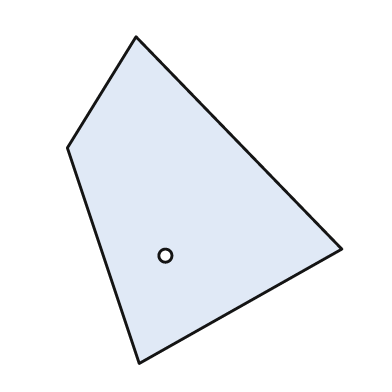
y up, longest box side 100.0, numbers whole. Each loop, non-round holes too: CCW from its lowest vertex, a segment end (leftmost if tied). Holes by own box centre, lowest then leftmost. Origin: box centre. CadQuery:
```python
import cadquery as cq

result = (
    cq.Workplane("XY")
    .moveTo(-20.0, -50.0)
    .lineTo(42.0, -15.0)
    .lineTo(-21.0, 50.0)
    .lineTo(-42.0, 16.0)
    .close()
    .moveTo(-12.0, -17.0)
    .circle(2.0)
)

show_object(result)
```